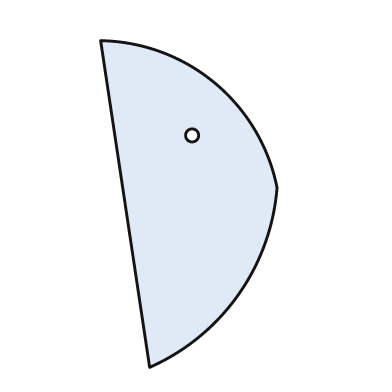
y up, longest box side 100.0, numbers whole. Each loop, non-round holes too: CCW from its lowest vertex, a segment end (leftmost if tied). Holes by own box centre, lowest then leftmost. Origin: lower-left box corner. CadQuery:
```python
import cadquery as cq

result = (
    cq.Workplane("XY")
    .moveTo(15.0, 0.0)
    .threePointArc((42.0, 22.0), (54.0, 55.0))
    .threePointArc((35.0, 87.0), (0.0, 100.0))
    .close()
    .moveTo(28.0, 71.0)
    .circle(2.0)
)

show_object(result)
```